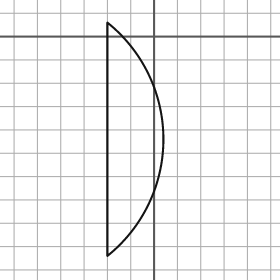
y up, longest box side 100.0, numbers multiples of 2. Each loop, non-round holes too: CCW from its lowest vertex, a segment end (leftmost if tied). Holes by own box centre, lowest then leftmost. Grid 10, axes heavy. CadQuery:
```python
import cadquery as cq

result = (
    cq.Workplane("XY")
    .moveTo(-20.0, -94.0)
    .threePointArc((4.0, -44.0), (-20.0, 6.0))
    .close()
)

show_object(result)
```